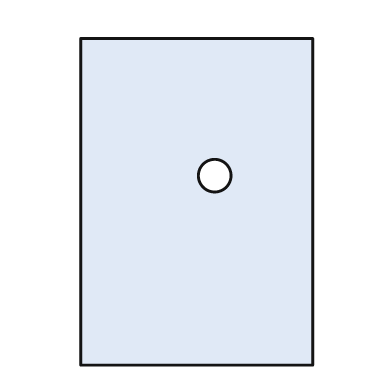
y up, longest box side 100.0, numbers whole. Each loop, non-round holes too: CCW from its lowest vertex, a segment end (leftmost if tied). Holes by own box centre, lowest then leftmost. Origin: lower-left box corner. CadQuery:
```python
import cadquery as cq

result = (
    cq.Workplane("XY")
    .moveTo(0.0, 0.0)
    .lineTo(71.0, 0.0)
    .lineTo(71.0, 100.0)
    .lineTo(0.0, 100.0)
    .close()
    .moveTo(41.0, 58.0)
    .circle(5.0)
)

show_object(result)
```